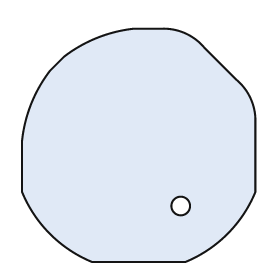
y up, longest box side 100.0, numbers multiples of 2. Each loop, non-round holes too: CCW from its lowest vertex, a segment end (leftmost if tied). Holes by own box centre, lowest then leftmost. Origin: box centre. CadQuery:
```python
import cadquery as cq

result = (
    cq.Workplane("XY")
    .moveTo(-20.0, -50.0)
    .lineTo(20.0, -50.0)
    .threePointArc((38.0, -38.0), (50.0, -20.0))
    .lineTo(50.0, 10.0)
    .threePointArc((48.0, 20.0), (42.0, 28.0))
    .lineTo(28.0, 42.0)
    .threePointArc((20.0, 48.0), (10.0, 50.0))
    .lineTo(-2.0, 50.0)
    .threePointArc((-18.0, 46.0), (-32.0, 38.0))
    .lineTo(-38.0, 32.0)
    .threePointArc((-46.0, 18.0), (-50.0, 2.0))
    .lineTo(-50.0, -20.0)
    .threePointArc((-38.0, -38.0), (-20.0, -50.0))
    .close()
    .moveTo(18.0, -26.0)
    .circle(4.0)
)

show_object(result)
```